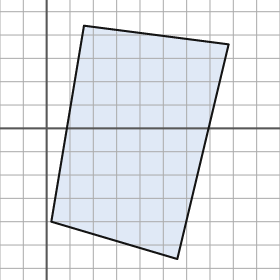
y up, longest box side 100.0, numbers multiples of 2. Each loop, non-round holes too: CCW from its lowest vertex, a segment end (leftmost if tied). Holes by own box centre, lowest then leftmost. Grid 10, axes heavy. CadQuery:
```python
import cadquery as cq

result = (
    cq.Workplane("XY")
    .moveTo(56.0, -56.0)
    .lineTo(78.0, 36.0)
    .lineTo(16.0, 44.0)
    .lineTo(2.0, -40.0)
    .close()
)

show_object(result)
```